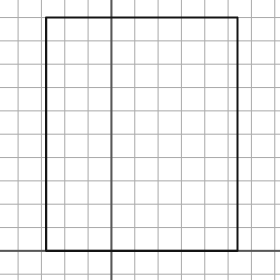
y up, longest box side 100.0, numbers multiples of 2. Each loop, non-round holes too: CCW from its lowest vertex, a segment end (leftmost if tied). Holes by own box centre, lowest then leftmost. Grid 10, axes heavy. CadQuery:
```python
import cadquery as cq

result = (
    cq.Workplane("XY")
    .moveTo(-28.0, 0.0)
    .lineTo(54.0, 0.0)
    .lineTo(54.0, 100.0)
    .lineTo(-28.0, 100.0)
    .close()
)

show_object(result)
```